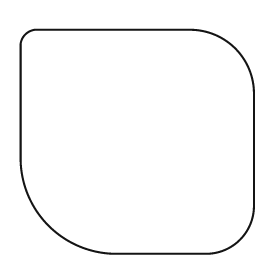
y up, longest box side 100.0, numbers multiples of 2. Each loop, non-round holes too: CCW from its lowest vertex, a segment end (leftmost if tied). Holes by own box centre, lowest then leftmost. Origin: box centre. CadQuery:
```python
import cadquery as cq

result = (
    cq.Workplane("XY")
    .moveTo(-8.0, -48.0)
    .lineTo(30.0, -48.0)
    .threePointArc((44.0, -42.0), (50.0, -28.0))
    .lineTo(50.0, 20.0)
    .threePointArc((42.0, 40.0), (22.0, 48.0))
    .lineTo(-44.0, 48.0)
    .threePointArc((-48.0, 46.0), (-50.0, 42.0))
    .lineTo(-50.0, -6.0)
    .threePointArc((-38.0, -36.0), (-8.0, -48.0))
    .close()
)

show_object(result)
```